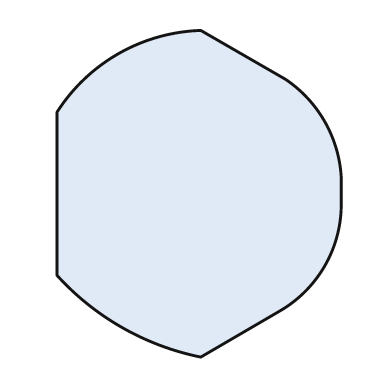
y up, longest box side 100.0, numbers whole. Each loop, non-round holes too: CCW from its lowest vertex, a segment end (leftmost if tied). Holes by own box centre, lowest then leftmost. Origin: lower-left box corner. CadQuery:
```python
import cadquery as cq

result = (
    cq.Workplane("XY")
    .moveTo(44.0, 0.0)
    .lineTo(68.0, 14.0)
    .threePointArc((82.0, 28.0), (87.0, 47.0))
    .lineTo(87.0, 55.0)
    .threePointArc((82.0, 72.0), (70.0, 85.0))
    .lineTo(44.0, 100.0)
    .threePointArc((19.0, 93.0), (0.0, 75.0))
    .lineTo(0.0, 25.0)
    .threePointArc((20.0, 9.0), (44.0, 0.0))
    .close()
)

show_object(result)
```